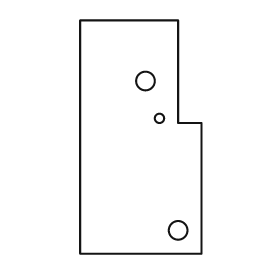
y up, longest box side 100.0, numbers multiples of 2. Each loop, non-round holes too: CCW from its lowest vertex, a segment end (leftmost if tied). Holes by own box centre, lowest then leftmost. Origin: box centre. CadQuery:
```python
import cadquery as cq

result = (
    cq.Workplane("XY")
    .moveTo(-26.0, -50.0)
    .lineTo(26.0, -50.0)
    .lineTo(26.0, 6.0)
    .lineTo(16.0, 6.0)
    .lineTo(16.0, 50.0)
    .lineTo(-26.0, 50.0)
    .close()
    .moveTo(16.0, -40.0)
    .circle(4.0)
    .moveTo(8.0, 8.0)
    .circle(2.0)
    .moveTo(2.0, 24.0)
    .circle(4.0)
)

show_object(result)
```